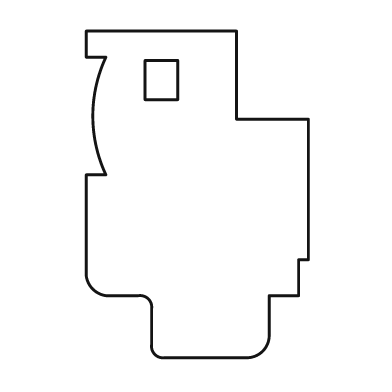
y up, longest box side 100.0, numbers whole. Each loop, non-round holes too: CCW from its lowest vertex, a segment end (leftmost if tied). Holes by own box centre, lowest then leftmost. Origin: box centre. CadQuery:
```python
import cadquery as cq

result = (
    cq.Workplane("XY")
    .moveTo(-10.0, -50.0)
    .lineTo(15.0, -50.0)
    .threePointArc((20.0, -48.0), (22.0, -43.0))
    .lineTo(22.0, -31.0)
    .lineTo(31.0, -31.0)
    .lineTo(31.0, -20.0)
    .lineTo(34.0, -20.0)
    .lineTo(34.0, 23.0)
    .lineTo(12.0, 23.0)
    .lineTo(12.0, 50.0)
    .lineTo(-34.0, 50.0)
    .lineTo(-34.0, 42.0)
    .lineTo(-28.0, 42.0)
    .threePointArc((-32.0, 24.0), (-28.0, 6.0))
    .lineTo(-34.0, 6.0)
    .lineTo(-34.0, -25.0)
    .threePointArc((-32.0, -29.0), (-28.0, -31.0))
    .lineTo(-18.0, -31.0)
    .threePointArc((-15.0, -32.0), (-14.0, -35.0))
    .lineTo(-14.0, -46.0)
    .threePointArc((-13.0, -49.0), (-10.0, -50.0))
    .close()
    .moveTo(-16.0, 29.0)
    .lineTo(-6.0, 29.0)
    .lineTo(-6.0, 41.0)
    .lineTo(-16.0, 41.0)
    .close()
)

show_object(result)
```